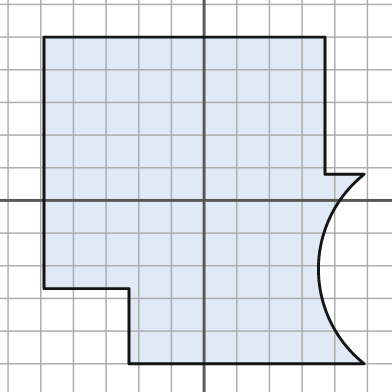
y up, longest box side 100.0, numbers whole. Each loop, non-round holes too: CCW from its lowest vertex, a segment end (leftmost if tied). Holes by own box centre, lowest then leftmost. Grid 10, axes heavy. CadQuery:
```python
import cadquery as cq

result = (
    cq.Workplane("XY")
    .moveTo(-23.0, -50.0)
    .lineTo(49.0, -50.0)
    .threePointArc((35.0, -21.0), (49.0, 8.0))
    .lineTo(37.0, 8.0)
    .lineTo(37.0, 50.0)
    .lineTo(-49.0, 50.0)
    .lineTo(-49.0, -27.0)
    .lineTo(-23.0, -27.0)
    .close()
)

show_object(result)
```